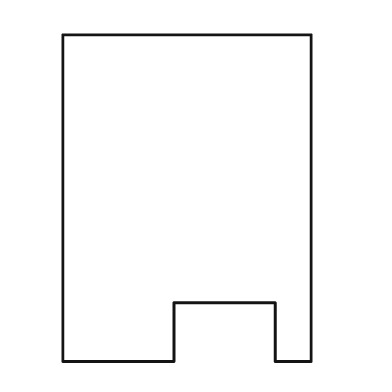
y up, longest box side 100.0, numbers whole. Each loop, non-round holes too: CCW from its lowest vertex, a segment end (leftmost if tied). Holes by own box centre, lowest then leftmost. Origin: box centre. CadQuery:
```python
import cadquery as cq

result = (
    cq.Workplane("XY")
    .moveTo(-38.0, -50.0)
    .lineTo(-4.0, -50.0)
    .lineTo(-4.0, -32.0)
    .lineTo(27.0, -32.0)
    .lineTo(27.0, -50.0)
    .lineTo(38.0, -50.0)
    .lineTo(38.0, 50.0)
    .lineTo(-38.0, 50.0)
    .close()
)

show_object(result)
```